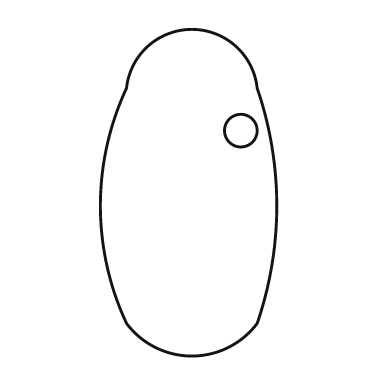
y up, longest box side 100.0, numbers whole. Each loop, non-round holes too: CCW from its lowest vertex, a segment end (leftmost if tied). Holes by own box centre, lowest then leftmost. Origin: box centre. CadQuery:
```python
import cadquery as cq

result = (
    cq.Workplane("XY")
    .moveTo(-19.0, -40.0)
    .threePointArc((1.0, -50.0), (21.0, -40.0))
    .threePointArc((27.0, -4.0), (21.0, 32.0))
    .threePointArc((1.0, 50.0), (-19.0, 32.0))
    .threePointArc((-27.0, -4.0), (-19.0, -40.0))
    .close()
    .moveTo(16.0, 19.0)
    .circle(5.0)
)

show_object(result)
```